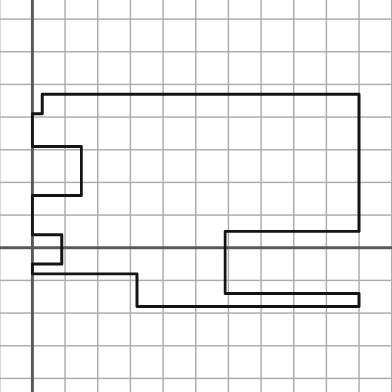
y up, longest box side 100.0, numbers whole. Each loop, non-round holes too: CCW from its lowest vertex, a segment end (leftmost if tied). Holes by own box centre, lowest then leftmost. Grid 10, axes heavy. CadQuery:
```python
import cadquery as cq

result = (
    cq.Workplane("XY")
    .moveTo(32.0, -18.0)
    .lineTo(100.0, -18.0)
    .lineTo(100.0, -14.0)
    .lineTo(59.0, -14.0)
    .lineTo(59.0, 5.0)
    .lineTo(100.0, 5.0)
    .lineTo(100.0, 47.0)
    .lineTo(3.0, 47.0)
    .lineTo(3.0, 41.0)
    .lineTo(0.0, 41.0)
    .lineTo(0.0, 31.0)
    .lineTo(15.0, 31.0)
    .lineTo(15.0, 16.0)
    .lineTo(0.0, 16.0)
    .lineTo(0.0, 4.0)
    .lineTo(9.0, 4.0)
    .lineTo(9.0, -5.0)
    .lineTo(0.0, -5.0)
    .lineTo(0.0, -8.0)
    .lineTo(32.0, -8.0)
    .close()
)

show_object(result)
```